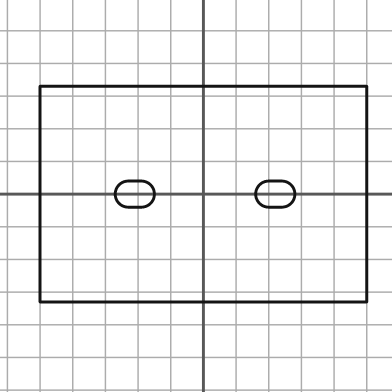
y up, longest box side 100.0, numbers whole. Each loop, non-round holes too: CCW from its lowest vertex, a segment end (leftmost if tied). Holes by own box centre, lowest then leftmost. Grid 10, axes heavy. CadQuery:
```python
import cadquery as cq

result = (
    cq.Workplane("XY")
    .moveTo(-50.0, -33.0)
    .lineTo(50.0, -33.0)
    .lineTo(50.0, 33.0)
    .lineTo(-50.0, 33.0)
    .close()
    .moveTo(-23.0, -4.0)
    .lineTo(-19.0, -4.0)
    .threePointArc((-15.0, 0.0), (-19.0, 4.0))
    .lineTo(-23.0, 4.0)
    .threePointArc((-27.0, 0.0), (-23.0, -4.0))
    .close()
    .moveTo(20.0, -4.0)
    .lineTo(24.0, -4.0)
    .threePointArc((28.0, 0.0), (24.0, 4.0))
    .lineTo(20.0, 4.0)
    .threePointArc((16.0, 0.0), (20.0, -4.0))
    .close()
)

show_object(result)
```